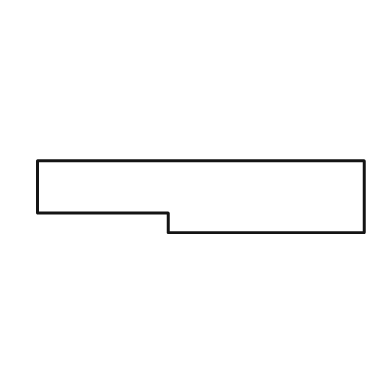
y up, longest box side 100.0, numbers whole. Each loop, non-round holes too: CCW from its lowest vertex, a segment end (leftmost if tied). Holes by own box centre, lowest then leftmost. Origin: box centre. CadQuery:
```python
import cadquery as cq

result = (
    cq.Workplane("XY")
    .moveTo(-10.0, -11.0)
    .lineTo(50.0, -11.0)
    .lineTo(50.0, 11.0)
    .lineTo(-50.0, 11.0)
    .lineTo(-50.0, -5.0)
    .lineTo(-10.0, -5.0)
    .close()
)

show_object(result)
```